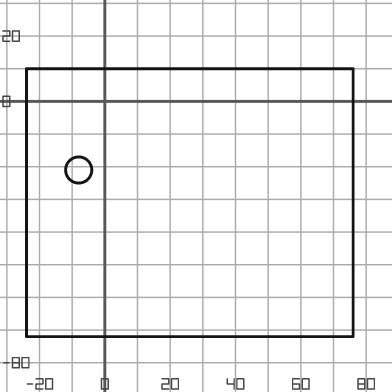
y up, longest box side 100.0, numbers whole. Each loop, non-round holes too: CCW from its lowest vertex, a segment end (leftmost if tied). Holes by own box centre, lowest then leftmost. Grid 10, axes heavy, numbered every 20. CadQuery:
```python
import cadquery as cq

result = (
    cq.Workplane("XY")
    .moveTo(-24.0, -72.0)
    .lineTo(76.0, -72.0)
    .lineTo(76.0, 10.0)
    .lineTo(-24.0, 10.0)
    .close()
    .moveTo(-8.0, -21.0)
    .circle(4.0)
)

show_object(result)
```